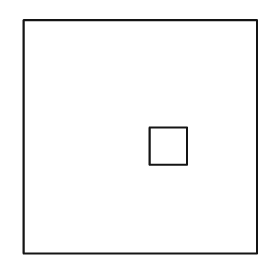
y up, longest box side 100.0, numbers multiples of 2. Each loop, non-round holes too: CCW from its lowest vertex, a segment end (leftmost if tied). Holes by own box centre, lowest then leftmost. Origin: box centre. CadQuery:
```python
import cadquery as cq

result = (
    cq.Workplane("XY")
    .moveTo(-50.0, -50.0)
    .lineTo(50.0, -50.0)
    .lineTo(50.0, 50.0)
    .lineTo(-50.0, 50.0)
    .close()
    .moveTo(4.0, -12.0)
    .lineTo(20.0, -12.0)
    .lineTo(20.0, 4.0)
    .lineTo(4.0, 4.0)
    .close()
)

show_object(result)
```